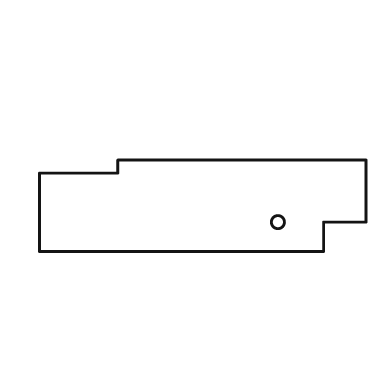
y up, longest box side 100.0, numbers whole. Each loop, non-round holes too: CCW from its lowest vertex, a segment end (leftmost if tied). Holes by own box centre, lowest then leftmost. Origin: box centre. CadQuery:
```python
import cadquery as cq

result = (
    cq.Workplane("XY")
    .moveTo(-50.0, -14.0)
    .lineTo(37.0, -14.0)
    .lineTo(37.0, -5.0)
    .lineTo(50.0, -5.0)
    .lineTo(50.0, 14.0)
    .lineTo(-26.0, 14.0)
    .lineTo(-26.0, 10.0)
    .lineTo(-50.0, 10.0)
    .close()
    .moveTo(23.0, -5.0)
    .circle(2.0)
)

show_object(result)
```